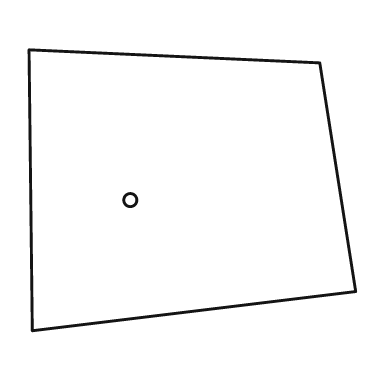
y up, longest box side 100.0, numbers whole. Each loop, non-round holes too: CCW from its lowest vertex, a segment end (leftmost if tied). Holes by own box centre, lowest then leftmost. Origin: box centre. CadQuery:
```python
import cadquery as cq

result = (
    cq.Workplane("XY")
    .moveTo(-49.0, -43.0)
    .lineTo(50.0, -31.0)
    .lineTo(39.0, 39.0)
    .lineTo(-50.0, 43.0)
    .close()
    .moveTo(-19.0, -3.0)
    .circle(2.0)
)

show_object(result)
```